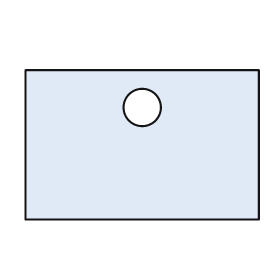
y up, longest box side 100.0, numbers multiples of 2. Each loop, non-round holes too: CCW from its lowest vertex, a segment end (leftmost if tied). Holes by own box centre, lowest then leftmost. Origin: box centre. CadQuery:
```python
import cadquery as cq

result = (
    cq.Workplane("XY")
    .moveTo(-50.0, -32.0)
    .lineTo(50.0, -32.0)
    .lineTo(50.0, 32.0)
    .lineTo(-50.0, 32.0)
    .close()
    .moveTo(0.0, 16.0)
    .circle(8.0)
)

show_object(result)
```